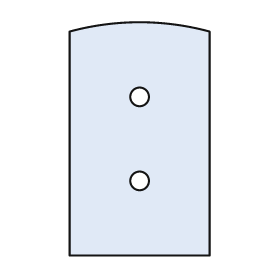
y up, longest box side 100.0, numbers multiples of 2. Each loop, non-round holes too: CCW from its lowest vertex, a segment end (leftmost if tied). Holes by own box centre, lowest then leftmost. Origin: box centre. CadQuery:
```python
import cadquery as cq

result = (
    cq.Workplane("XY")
    .moveTo(-30.0, -50.0)
    .lineTo(30.0, -50.0)
    .lineTo(30.0, 46.0)
    .threePointArc((0.0, 50.0), (-30.0, 46.0))
    .close()
    .moveTo(0.0, -18.0)
    .circle(4.0)
    .moveTo(0.0, 18.0)
    .circle(4.0)
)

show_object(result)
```